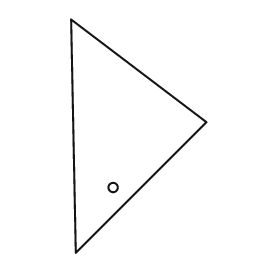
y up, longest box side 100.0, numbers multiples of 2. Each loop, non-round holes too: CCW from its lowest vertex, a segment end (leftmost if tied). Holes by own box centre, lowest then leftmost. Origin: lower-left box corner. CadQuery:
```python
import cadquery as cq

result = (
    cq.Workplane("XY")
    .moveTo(2.0, 0.0)
    .lineTo(58.0, 56.0)
    .lineTo(0.0, 100.0)
    .close()
    .moveTo(18.0, 28.0)
    .circle(2.0)
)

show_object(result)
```